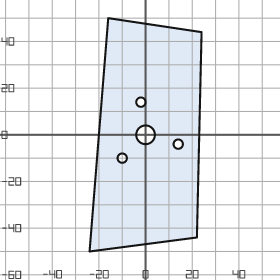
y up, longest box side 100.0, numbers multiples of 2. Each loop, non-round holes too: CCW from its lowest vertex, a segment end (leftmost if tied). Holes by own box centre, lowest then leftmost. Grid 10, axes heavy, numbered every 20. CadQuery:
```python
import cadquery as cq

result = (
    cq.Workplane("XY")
    .moveTo(-24.0, -50.0)
    .lineTo(22.0, -44.0)
    .lineTo(24.0, 44.0)
    .lineTo(-16.0, 50.0)
    .close()
    .moveTo(-10.0, -10.0)
    .circle(2.0)
    .moveTo(14.0, -4.0)
    .circle(2.0)
    .moveTo(0.0, 0.0)
    .circle(4.0)
    .moveTo(-2.0, 14.0)
    .circle(2.0)
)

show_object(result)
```